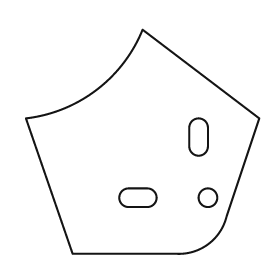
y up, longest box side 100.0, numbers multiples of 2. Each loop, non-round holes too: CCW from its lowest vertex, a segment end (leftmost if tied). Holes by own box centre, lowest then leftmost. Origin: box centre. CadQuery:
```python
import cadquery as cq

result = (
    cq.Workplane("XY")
    .moveTo(-30.0, -48.0)
    .lineTo(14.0, -48.0)
    .threePointArc((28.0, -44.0), (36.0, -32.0))
    .lineTo(50.0, 10.0)
    .lineTo(0.0, 48.0)
    .threePointArc((-20.0, 22.0), (-50.0, 10.0))
    .close()
    .moveTo(-6.0, -28.0)
    .lineTo(2.0, -28.0)
    .threePointArc((6.0, -24.0), (2.0, -20.0))
    .lineTo(-6.0, -20.0)
    .threePointArc((-10.0, -24.0), (-6.0, -28.0))
    .close()
    .moveTo(28.0, -24.0)
    .circle(4.0)
    .moveTo(20.0, -2.0)
    .threePointArc((24.0, -6.0), (28.0, -2.0))
    .lineTo(28.0, 6.0)
    .threePointArc((24.0, 10.0), (20.0, 6.0))
    .close()
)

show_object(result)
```